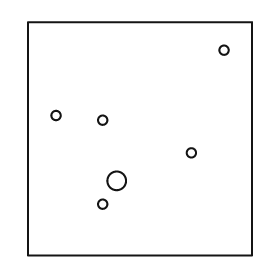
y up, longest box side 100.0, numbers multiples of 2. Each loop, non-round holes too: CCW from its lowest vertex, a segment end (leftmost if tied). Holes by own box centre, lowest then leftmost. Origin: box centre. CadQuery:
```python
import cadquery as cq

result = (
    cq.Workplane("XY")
    .moveTo(-48.0, -50.0)
    .lineTo(48.0, -50.0)
    .lineTo(48.0, 50.0)
    .lineTo(-48.0, 50.0)
    .close()
    .moveTo(-16.0, -28.0)
    .circle(2.0)
    .moveTo(-10.0, -18.0)
    .circle(4.0)
    .moveTo(22.0, -6.0)
    .circle(2.0)
    .moveTo(-16.0, 8.0)
    .circle(2.0)
    .moveTo(-36.0, 10.0)
    .circle(2.0)
    .moveTo(36.0, 38.0)
    .circle(2.0)
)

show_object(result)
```